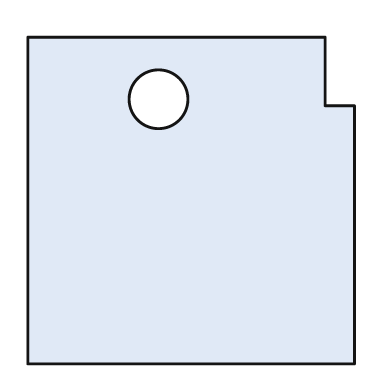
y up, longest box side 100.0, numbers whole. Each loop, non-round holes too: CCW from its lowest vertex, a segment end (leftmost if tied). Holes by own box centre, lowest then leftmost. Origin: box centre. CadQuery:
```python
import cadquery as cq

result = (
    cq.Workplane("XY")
    .moveTo(-50.0, -50.0)
    .lineTo(50.0, -50.0)
    .lineTo(50.0, 29.0)
    .lineTo(41.0, 29.0)
    .lineTo(41.0, 50.0)
    .lineTo(-50.0, 50.0)
    .close()
    .moveTo(-10.0, 31.0)
    .circle(9.0)
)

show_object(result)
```